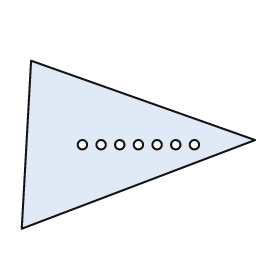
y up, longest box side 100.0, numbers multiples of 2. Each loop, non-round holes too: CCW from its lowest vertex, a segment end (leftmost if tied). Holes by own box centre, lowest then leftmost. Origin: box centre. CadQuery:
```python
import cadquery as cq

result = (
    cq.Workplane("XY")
    .moveTo(-50.0, -36.0)
    .lineTo(50.0, 2.0)
    .lineTo(-46.0, 36.0)
    .close()
    .moveTo(-24.0, 0.0)
    .circle(2.0)
    .moveTo(-16.0, 0.0)
    .circle(2.0)
    .moveTo(-8.0, 0.0)
    .circle(2.0)
    .moveTo(0.0, 0.0)
    .circle(2.0)
    .moveTo(8.0, 0.0)
    .circle(2.0)
    .moveTo(16.0, 0.0)
    .circle(2.0)
    .moveTo(24.0, 0.0)
    .circle(2.0)
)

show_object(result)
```